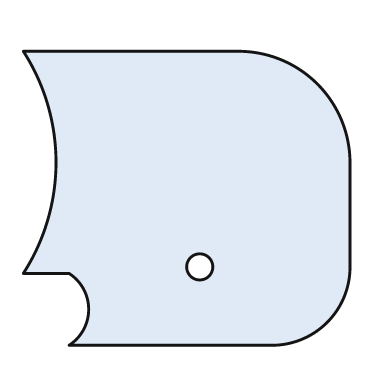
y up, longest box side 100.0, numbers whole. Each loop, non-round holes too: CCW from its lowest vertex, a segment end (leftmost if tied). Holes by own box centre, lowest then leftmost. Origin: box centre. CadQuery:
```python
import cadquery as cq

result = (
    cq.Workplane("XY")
    .moveTo(-36.0, -45.0)
    .lineTo(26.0, -45.0)
    .threePointArc((43.0, -38.0), (50.0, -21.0))
    .lineTo(50.0, 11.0)
    .threePointArc((40.0, 35.0), (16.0, 45.0))
    .lineTo(-50.0, 45.0)
    .threePointArc((-40.0, 11.0), (-50.0, -23.0))
    .lineTo(-36.0, -23.0)
    .threePointArc((-30.0, -34.0), (-36.0, -45.0))
    .close()
    .moveTo(4.0, -21.0)
    .circle(4.0)
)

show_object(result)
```